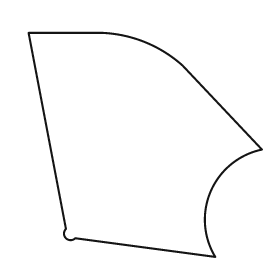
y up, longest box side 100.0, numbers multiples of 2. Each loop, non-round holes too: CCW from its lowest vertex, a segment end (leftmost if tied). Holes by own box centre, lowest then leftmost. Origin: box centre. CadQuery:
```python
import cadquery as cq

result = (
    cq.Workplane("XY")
    .moveTo(30.0, -48.0)
    .threePointArc((28.0, -20.0), (50.0, -2.0))
    .lineTo(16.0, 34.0)
    .threePointArc((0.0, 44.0), (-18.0, 48.0))
    .lineTo(-50.0, 48.0)
    .lineTo(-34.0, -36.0)
    .threePointArc((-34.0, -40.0), (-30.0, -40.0))
    .close()
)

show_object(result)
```